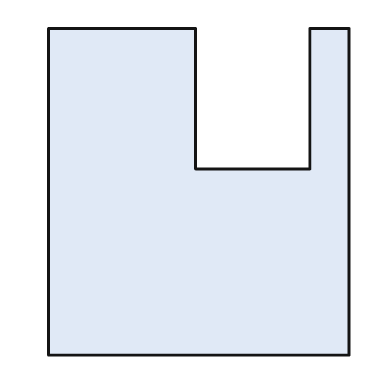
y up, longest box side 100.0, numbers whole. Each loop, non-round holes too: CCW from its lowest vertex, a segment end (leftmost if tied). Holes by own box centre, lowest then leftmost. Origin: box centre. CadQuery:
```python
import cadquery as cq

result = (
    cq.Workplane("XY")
    .moveTo(-46.0, -50.0)
    .lineTo(46.0, -50.0)
    .lineTo(46.0, 50.0)
    .lineTo(34.0, 50.0)
    .lineTo(34.0, 7.0)
    .lineTo(-1.0, 7.0)
    .lineTo(-1.0, 50.0)
    .lineTo(-46.0, 50.0)
    .close()
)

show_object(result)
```